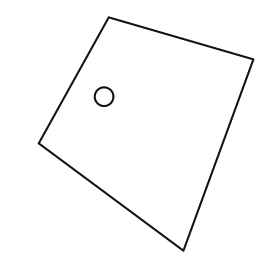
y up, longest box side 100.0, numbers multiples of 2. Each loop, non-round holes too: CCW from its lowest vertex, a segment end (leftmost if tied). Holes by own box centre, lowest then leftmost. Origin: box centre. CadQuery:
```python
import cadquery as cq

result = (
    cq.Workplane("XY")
    .moveTo(16.0, -50.0)
    .lineTo(46.0, 32.0)
    .lineTo(-16.0, 50.0)
    .lineTo(-46.0, -4.0)
    .close()
    .moveTo(-18.0, 16.0)
    .circle(4.0)
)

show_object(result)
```